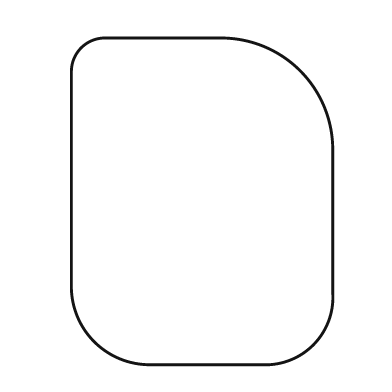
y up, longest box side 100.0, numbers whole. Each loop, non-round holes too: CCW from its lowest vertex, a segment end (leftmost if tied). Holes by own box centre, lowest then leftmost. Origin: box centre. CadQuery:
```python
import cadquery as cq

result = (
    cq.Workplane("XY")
    .moveTo(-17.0, -50.0)
    .lineTo(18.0, -50.0)
    .threePointArc((34.0, -44.0), (40.0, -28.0))
    .lineTo(40.0, 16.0)
    .threePointArc((30.0, 40.0), (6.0, 50.0))
    .lineTo(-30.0, 50.0)
    .threePointArc((-37.0, 47.0), (-40.0, 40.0))
    .lineTo(-40.0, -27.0)
    .threePointArc((-33.0, -43.0), (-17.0, -50.0))
    .close()
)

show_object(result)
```